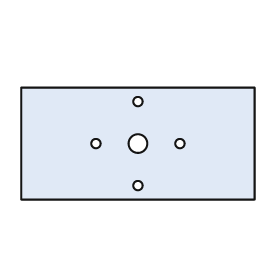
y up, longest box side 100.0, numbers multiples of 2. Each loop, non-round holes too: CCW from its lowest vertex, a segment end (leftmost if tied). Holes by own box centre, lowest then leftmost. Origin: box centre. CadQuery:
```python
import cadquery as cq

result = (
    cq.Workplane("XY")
    .moveTo(-50.0, -24.0)
    .lineTo(50.0, -24.0)
    .lineTo(50.0, 24.0)
    .lineTo(-50.0, 24.0)
    .close()
    .moveTo(0.0, -18.0)
    .circle(2.0)
    .moveTo(-18.0, 0.0)
    .circle(2.0)
    .moveTo(0.0, 0.0)
    .circle(4.0)
    .moveTo(18.0, 0.0)
    .circle(2.0)
    .moveTo(0.0, 18.0)
    .circle(2.0)
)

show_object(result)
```